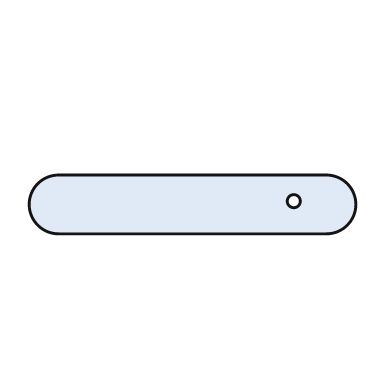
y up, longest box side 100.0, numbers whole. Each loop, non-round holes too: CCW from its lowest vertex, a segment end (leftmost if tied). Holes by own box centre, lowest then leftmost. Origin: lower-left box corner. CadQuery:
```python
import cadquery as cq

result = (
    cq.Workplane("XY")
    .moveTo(9.0, 0.0)
    .lineTo(91.0, 0.0)
    .threePointArc((100.0, 9.0), (91.0, 18.0))
    .lineTo(9.0, 18.0)
    .threePointArc((0.0, 9.0), (9.0, 0.0))
    .close()
    .moveTo(81.0, 10.0)
    .circle(2.0)
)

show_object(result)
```